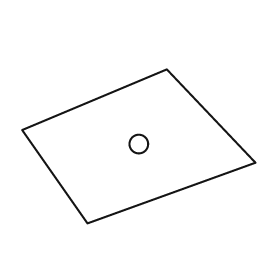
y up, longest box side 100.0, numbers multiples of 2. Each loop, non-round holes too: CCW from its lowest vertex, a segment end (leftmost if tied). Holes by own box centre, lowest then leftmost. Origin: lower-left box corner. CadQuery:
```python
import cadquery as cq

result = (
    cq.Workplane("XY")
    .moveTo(28.0, 0.0)
    .lineTo(100.0, 26.0)
    .lineTo(62.0, 66.0)
    .lineTo(0.0, 40.0)
    .close()
    .moveTo(50.0, 34.0)
    .circle(4.0)
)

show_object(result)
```